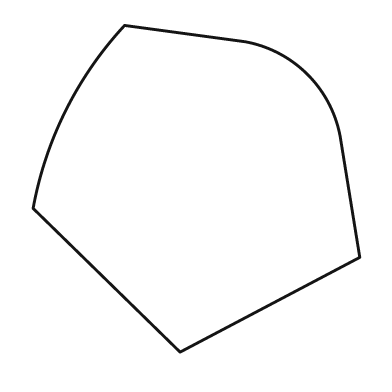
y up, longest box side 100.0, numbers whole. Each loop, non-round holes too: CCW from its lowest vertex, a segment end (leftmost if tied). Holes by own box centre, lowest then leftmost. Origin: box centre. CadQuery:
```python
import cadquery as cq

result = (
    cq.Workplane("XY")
    .moveTo(-5.0, -50.0)
    .lineTo(50.0, -21.0)
    .lineTo(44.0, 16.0)
    .threePointArc((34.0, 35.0), (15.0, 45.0))
    .lineTo(-22.0, 50.0)
    .threePointArc((-40.0, 24.0), (-50.0, -6.0))
    .close()
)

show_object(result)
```